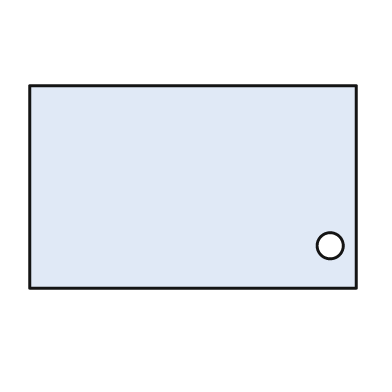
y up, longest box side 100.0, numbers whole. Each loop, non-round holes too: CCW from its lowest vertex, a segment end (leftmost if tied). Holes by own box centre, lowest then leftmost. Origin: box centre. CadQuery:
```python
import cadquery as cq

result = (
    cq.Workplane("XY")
    .moveTo(-50.0, -31.0)
    .lineTo(50.0, -31.0)
    .lineTo(50.0, 31.0)
    .lineTo(-50.0, 31.0)
    .close()
    .moveTo(42.0, -18.0)
    .circle(4.0)
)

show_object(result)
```